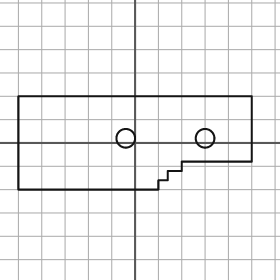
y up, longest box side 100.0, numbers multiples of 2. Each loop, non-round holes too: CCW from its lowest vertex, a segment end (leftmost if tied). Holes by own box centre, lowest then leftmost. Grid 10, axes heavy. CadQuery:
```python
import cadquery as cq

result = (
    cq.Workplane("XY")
    .moveTo(-50.0, -20.0)
    .lineTo(10.0, -20.0)
    .lineTo(10.0, -16.0)
    .lineTo(14.0, -16.0)
    .lineTo(14.0, -12.0)
    .lineTo(20.0, -12.0)
    .lineTo(20.0, -8.0)
    .lineTo(50.0, -8.0)
    .lineTo(50.0, 20.0)
    .lineTo(-50.0, 20.0)
    .close()
    .moveTo(-4.0, 2.0)
    .circle(4.0)
    .moveTo(30.0, 2.0)
    .circle(4.0)
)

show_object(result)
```